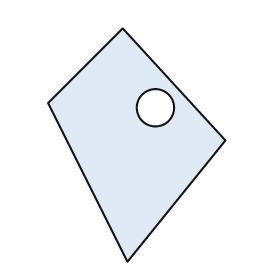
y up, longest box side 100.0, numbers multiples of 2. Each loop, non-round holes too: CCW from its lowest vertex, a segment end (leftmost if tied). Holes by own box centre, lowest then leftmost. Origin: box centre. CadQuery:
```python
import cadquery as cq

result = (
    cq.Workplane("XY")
    .moveTo(-4.0, -50.0)
    .lineTo(38.0, 2.0)
    .lineTo(-6.0, 50.0)
    .lineTo(-38.0, 18.0)
    .close()
    .moveTo(8.0, 16.0)
    .circle(8.0)
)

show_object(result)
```